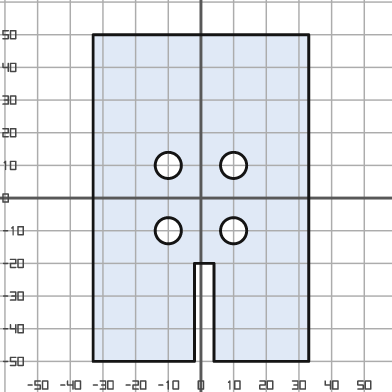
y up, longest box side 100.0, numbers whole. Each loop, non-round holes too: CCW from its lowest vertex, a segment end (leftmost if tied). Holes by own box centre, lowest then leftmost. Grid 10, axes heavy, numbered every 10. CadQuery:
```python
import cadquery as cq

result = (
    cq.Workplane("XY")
    .moveTo(-33.0, -50.0)
    .lineTo(-2.0, -50.0)
    .lineTo(-2.0, -20.0)
    .lineTo(4.0, -20.0)
    .lineTo(4.0, -50.0)
    .lineTo(33.0, -50.0)
    .lineTo(33.0, 50.0)
    .lineTo(-33.0, 50.0)
    .close()
    .moveTo(-10.0, -10.0)
    .circle(4.0)
    .moveTo(10.0, -10.0)
    .circle(4.0)
    .moveTo(-10.0, 10.0)
    .circle(4.0)
    .moveTo(10.0, 10.0)
    .circle(4.0)
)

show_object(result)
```